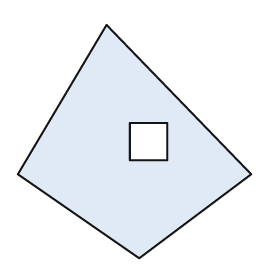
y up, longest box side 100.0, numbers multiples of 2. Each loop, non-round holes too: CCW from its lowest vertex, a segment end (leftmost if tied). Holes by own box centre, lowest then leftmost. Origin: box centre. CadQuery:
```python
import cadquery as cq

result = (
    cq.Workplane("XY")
    .moveTo(2.0, -50.0)
    .lineTo(50.0, -14.0)
    .lineTo(-12.0, 50.0)
    .lineTo(-50.0, -14.0)
    .close()
    .moveTo(-2.0, -8.0)
    .lineTo(14.0, -8.0)
    .lineTo(14.0, 8.0)
    .lineTo(-2.0, 8.0)
    .close()
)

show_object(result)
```